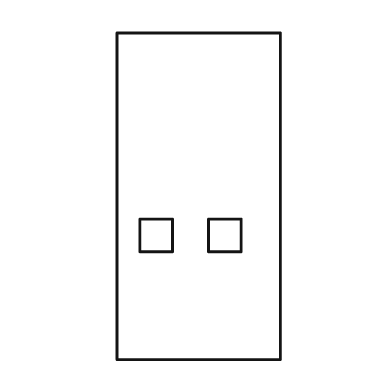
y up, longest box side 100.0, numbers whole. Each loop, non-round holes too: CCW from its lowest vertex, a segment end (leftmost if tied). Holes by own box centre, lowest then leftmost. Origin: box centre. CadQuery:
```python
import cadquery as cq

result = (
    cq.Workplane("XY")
    .moveTo(-25.0, -50.0)
    .lineTo(25.0, -50.0)
    .lineTo(25.0, 50.0)
    .lineTo(-25.0, 50.0)
    .close()
    .moveTo(-18.0, -17.0)
    .lineTo(-8.0, -17.0)
    .lineTo(-8.0, -7.0)
    .lineTo(-18.0, -7.0)
    .close()
    .moveTo(3.0, -17.0)
    .lineTo(13.0, -17.0)
    .lineTo(13.0, -7.0)
    .lineTo(3.0, -7.0)
    .close()
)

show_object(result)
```